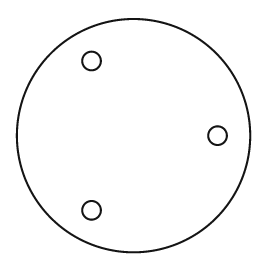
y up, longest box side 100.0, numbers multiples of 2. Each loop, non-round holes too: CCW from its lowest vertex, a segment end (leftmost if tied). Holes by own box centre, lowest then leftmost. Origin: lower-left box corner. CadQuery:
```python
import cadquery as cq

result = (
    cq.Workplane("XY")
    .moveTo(50.0, 50.0)
    .circle(50.0)
    .moveTo(32.0, 18.0)
    .circle(4.0)
    .moveTo(86.0, 50.0)
    .circle(4.0)
    .moveTo(32.0, 82.0)
    .circle(4.0)
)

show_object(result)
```